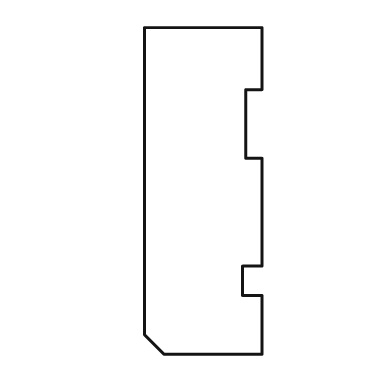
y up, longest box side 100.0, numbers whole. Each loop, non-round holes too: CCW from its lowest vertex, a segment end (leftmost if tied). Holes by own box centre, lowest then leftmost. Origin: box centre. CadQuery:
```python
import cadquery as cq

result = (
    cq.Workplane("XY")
    .moveTo(-12.0, -50.0)
    .lineTo(18.0, -50.0)
    .lineTo(18.0, -32.0)
    .lineTo(12.0, -32.0)
    .lineTo(12.0, -23.0)
    .lineTo(18.0, -23.0)
    .lineTo(18.0, 10.0)
    .lineTo(13.0, 10.0)
    .lineTo(13.0, 31.0)
    .lineTo(18.0, 31.0)
    .lineTo(18.0, 50.0)
    .lineTo(-18.0, 50.0)
    .lineTo(-18.0, -44.0)
    .close()
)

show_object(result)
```